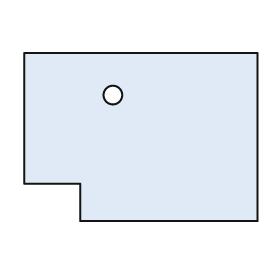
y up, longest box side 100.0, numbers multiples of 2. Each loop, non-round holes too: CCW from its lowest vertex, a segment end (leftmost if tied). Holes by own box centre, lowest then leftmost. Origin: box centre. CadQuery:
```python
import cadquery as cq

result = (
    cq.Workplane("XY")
    .moveTo(-26.0, -36.0)
    .lineTo(50.0, -36.0)
    .lineTo(50.0, 36.0)
    .lineTo(-50.0, 36.0)
    .lineTo(-50.0, -20.0)
    .lineTo(-26.0, -20.0)
    .close()
    .moveTo(-12.0, 18.0)
    .circle(4.0)
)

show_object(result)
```